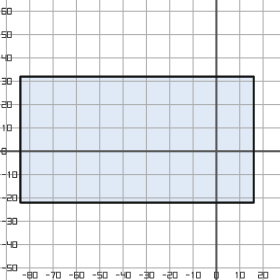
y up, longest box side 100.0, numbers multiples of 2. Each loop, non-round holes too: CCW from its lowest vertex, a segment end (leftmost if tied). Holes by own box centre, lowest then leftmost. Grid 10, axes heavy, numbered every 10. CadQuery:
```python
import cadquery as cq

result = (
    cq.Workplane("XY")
    .moveTo(-84.0, -22.0)
    .lineTo(16.0, -22.0)
    .lineTo(16.0, 32.0)
    .lineTo(-84.0, 32.0)
    .close()
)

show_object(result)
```